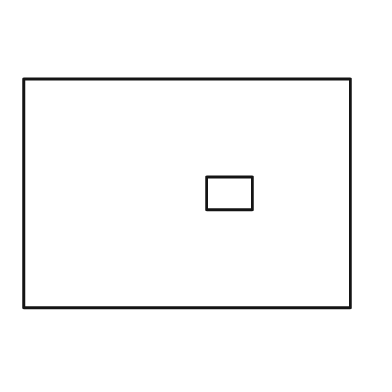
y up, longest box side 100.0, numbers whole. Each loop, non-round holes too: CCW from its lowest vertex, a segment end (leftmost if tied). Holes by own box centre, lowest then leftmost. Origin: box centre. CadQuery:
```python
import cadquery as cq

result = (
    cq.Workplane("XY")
    .moveTo(-50.0, -35.0)
    .lineTo(50.0, -35.0)
    .lineTo(50.0, 35.0)
    .lineTo(-50.0, 35.0)
    .close()
    .moveTo(6.0, -5.0)
    .lineTo(20.0, -5.0)
    .lineTo(20.0, 5.0)
    .lineTo(6.0, 5.0)
    .close()
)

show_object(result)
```